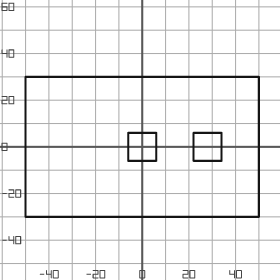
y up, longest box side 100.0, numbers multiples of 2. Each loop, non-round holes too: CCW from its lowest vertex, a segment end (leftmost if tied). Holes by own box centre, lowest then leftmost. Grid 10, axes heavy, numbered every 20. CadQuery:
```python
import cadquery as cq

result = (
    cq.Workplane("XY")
    .moveTo(-50.0, -30.0)
    .lineTo(50.0, -30.0)
    .lineTo(50.0, 30.0)
    .lineTo(-50.0, 30.0)
    .close()
    .moveTo(-6.0, -6.0)
    .lineTo(6.0, -6.0)
    .lineTo(6.0, 6.0)
    .lineTo(-6.0, 6.0)
    .close()
    .moveTo(22.0, -6.0)
    .lineTo(34.0, -6.0)
    .lineTo(34.0, 6.0)
    .lineTo(22.0, 6.0)
    .close()
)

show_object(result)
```